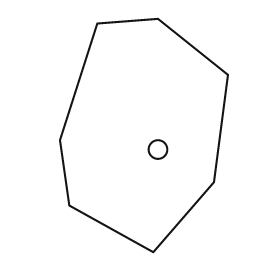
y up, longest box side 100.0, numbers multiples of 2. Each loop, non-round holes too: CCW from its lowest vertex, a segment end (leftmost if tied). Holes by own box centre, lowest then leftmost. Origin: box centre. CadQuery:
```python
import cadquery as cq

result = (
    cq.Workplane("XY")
    .moveTo(4.0, -50.0)
    .lineTo(30.0, -20.0)
    .lineTo(36.0, 26.0)
    .lineTo(6.0, 50.0)
    .lineTo(-20.0, 48.0)
    .lineTo(-36.0, -2.0)
    .lineTo(-32.0, -30.0)
    .close()
    .moveTo(6.0, -6.0)
    .circle(4.0)
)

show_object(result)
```